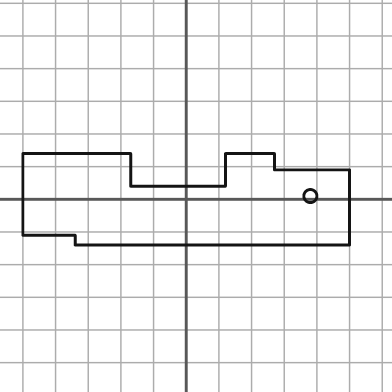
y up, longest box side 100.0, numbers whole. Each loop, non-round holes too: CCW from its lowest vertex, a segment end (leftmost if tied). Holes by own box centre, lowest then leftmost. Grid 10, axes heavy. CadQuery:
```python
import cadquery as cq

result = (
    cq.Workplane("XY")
    .moveTo(-34.0, -14.0)
    .lineTo(50.0, -14.0)
    .lineTo(50.0, 9.0)
    .lineTo(27.0, 9.0)
    .lineTo(27.0, 14.0)
    .lineTo(12.0, 14.0)
    .lineTo(12.0, 4.0)
    .lineTo(-17.0, 4.0)
    .lineTo(-17.0, 14.0)
    .lineTo(-50.0, 14.0)
    .lineTo(-50.0, -11.0)
    .lineTo(-34.0, -11.0)
    .close()
    .moveTo(38.0, 1.0)
    .circle(2.0)
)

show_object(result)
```